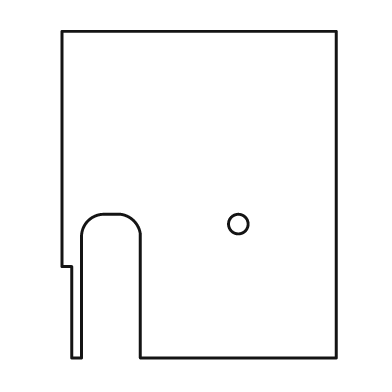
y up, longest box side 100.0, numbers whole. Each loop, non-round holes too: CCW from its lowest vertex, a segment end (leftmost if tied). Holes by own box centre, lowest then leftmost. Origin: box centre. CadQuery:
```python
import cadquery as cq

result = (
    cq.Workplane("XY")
    .moveTo(-39.0, -50.0)
    .lineTo(-36.0, -50.0)
    .lineTo(-36.0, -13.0)
    .threePointArc((-34.0, -8.0), (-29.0, -6.0))
    .lineTo(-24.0, -6.0)
    .threePointArc((-20.0, -8.0), (-18.0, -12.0))
    .lineTo(-18.0, -50.0)
    .lineTo(42.0, -50.0)
    .lineTo(42.0, 50.0)
    .lineTo(-42.0, 50.0)
    .lineTo(-42.0, -22.0)
    .lineTo(-39.0, -22.0)
    .close()
    .moveTo(12.0, -9.0)
    .circle(3.0)
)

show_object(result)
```